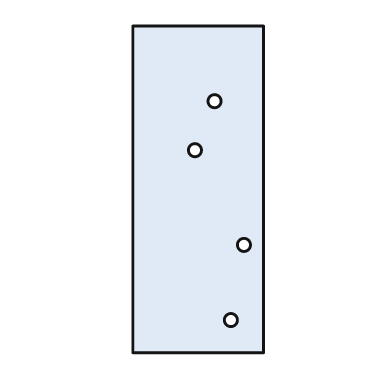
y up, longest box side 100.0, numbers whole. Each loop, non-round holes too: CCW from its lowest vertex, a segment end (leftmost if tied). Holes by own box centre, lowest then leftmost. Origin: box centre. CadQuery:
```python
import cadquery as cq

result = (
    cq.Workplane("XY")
    .moveTo(-20.0, -50.0)
    .lineTo(20.0, -50.0)
    .lineTo(20.0, 50.0)
    .lineTo(-20.0, 50.0)
    .close()
    .moveTo(10.0, -40.0)
    .circle(2.0)
    .moveTo(14.0, -17.0)
    .circle(2.0)
    .moveTo(-1.0, 12.0)
    .circle(2.0)
    .moveTo(5.0, 27.0)
    .circle(2.0)
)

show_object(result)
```